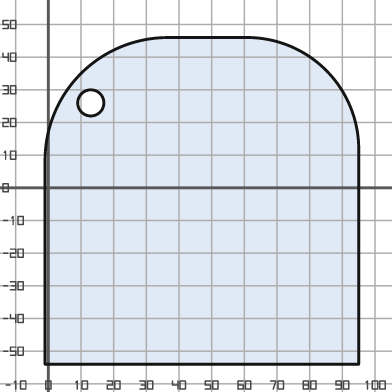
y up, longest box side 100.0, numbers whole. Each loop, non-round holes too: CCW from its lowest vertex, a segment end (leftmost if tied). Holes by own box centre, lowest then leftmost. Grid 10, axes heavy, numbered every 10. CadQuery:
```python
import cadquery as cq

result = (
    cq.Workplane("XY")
    .moveTo(-1.0, -54.0)
    .lineTo(95.0, -54.0)
    .lineTo(95.0, 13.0)
    .threePointArc((85.0, 36.0), (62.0, 46.0))
    .lineTo(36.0, 46.0)
    .threePointArc((10.0, 35.0), (-1.0, 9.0))
    .close()
    .moveTo(13.0, 26.0)
    .circle(4.0)
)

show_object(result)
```